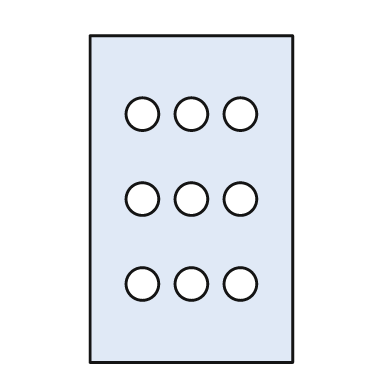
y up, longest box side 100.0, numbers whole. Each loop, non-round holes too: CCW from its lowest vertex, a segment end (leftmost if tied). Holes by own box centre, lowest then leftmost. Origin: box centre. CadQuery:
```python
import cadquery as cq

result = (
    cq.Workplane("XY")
    .moveTo(-31.0, -50.0)
    .lineTo(31.0, -50.0)
    .lineTo(31.0, 50.0)
    .lineTo(-31.0, 50.0)
    .close()
    .moveTo(-15.0, -26.0)
    .circle(5.0)
    .moveTo(0.0, -26.0)
    .circle(5.0)
    .moveTo(15.0, -26.0)
    .circle(5.0)
    .moveTo(-15.0, 0.0)
    .circle(5.0)
    .moveTo(0.0, 0.0)
    .circle(5.0)
    .moveTo(15.0, 0.0)
    .circle(5.0)
    .moveTo(-15.0, 26.0)
    .circle(5.0)
    .moveTo(0.0, 26.0)
    .circle(5.0)
    .moveTo(15.0, 26.0)
    .circle(5.0)
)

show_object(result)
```